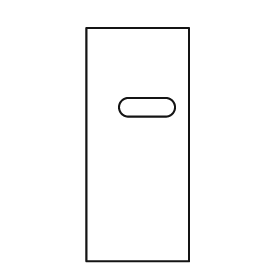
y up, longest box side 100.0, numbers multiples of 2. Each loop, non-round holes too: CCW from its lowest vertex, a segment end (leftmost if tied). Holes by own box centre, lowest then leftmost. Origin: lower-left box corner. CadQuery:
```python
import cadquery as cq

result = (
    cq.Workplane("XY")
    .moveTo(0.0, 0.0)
    .lineTo(44.0, 0.0)
    .lineTo(44.0, 100.0)
    .lineTo(0.0, 100.0)
    .close()
    .moveTo(18.0, 62.0)
    .lineTo(34.0, 62.0)
    .threePointArc((38.0, 66.0), (34.0, 70.0))
    .lineTo(18.0, 70.0)
    .threePointArc((14.0, 66.0), (18.0, 62.0))
    .close()
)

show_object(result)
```